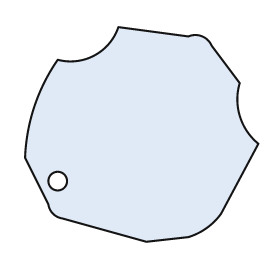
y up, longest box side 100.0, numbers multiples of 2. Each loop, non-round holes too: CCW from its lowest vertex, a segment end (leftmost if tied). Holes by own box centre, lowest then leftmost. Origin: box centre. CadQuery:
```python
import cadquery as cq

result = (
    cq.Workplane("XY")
    .moveTo(2.0, -46.0)
    .lineTo(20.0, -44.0)
    .threePointArc((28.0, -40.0), (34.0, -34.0))
    .lineTo(50.0, -4.0)
    .threePointArc((42.0, 8.0), (42.0, 22.0))
    .lineTo(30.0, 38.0)
    .threePointArc((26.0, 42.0), (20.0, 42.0))
    .lineTo(-10.0, 46.0)
    .threePointArc((-20.0, 34.0), (-36.0, 32.0))
    .threePointArc((-46.0, 12.0), (-50.0, -10.0))
    .lineTo(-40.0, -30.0)
    .threePointArc((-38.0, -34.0), (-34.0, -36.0))
    .close()
    .moveTo(-36.0, -20.0)
    .circle(4.0)
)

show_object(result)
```